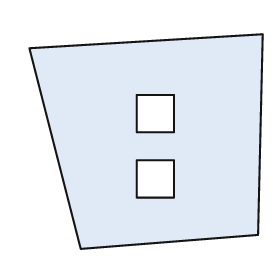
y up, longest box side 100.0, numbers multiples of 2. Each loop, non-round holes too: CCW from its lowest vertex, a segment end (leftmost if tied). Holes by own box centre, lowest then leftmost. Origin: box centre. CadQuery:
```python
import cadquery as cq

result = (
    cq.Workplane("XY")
    .moveTo(-28.0, -46.0)
    .lineTo(48.0, -40.0)
    .lineTo(50.0, 46.0)
    .lineTo(-50.0, 40.0)
    .close()
    .moveTo(-4.0, -24.0)
    .lineTo(12.0, -24.0)
    .lineTo(12.0, -8.0)
    .lineTo(-4.0, -8.0)
    .close()
    .moveTo(-4.0, 4.0)
    .lineTo(12.0, 4.0)
    .lineTo(12.0, 20.0)
    .lineTo(-4.0, 20.0)
    .close()
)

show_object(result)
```